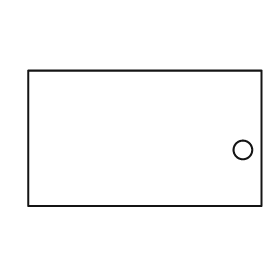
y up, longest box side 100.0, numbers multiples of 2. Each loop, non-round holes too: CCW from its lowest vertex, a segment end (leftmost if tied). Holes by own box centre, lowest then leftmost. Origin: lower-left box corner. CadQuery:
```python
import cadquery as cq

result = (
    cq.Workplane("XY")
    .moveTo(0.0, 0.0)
    .lineTo(100.0, 0.0)
    .lineTo(100.0, 58.0)
    .lineTo(0.0, 58.0)
    .close()
    .moveTo(92.0, 24.0)
    .circle(4.0)
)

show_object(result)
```